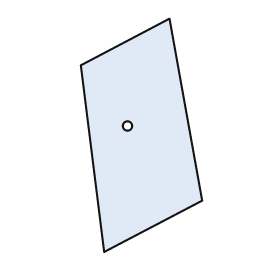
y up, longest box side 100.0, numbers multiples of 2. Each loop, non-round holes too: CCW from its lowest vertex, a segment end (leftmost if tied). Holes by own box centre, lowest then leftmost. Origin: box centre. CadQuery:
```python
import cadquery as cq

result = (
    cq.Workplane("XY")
    .moveTo(-16.0, -50.0)
    .lineTo(26.0, -28.0)
    .lineTo(12.0, 50.0)
    .lineTo(-26.0, 30.0)
    .close()
    .moveTo(-6.0, 4.0)
    .circle(2.0)
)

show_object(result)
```